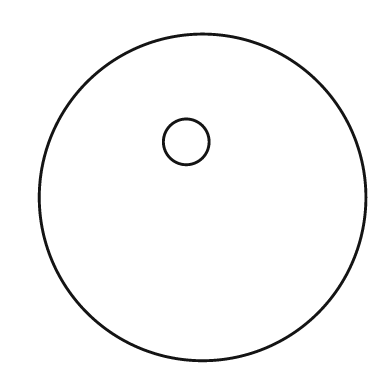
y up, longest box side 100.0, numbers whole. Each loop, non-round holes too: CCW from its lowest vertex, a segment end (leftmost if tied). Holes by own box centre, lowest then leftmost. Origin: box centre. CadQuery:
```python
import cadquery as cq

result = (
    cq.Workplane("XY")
    .moveTo(0.0, 0.0)
    .circle(50.0)
    .moveTo(-5.0, 17.0)
    .circle(7.0)
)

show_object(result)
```